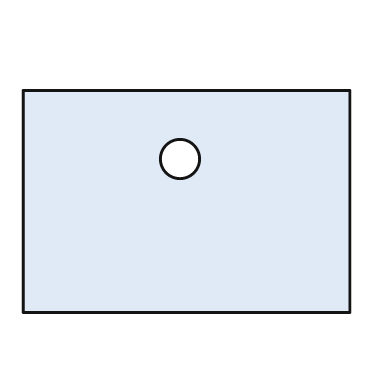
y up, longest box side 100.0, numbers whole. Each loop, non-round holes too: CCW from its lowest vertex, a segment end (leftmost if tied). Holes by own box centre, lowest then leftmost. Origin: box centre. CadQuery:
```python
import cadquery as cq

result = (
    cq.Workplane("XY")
    .moveTo(-50.0, -34.0)
    .lineTo(50.0, -34.0)
    .lineTo(50.0, 34.0)
    .lineTo(-50.0, 34.0)
    .close()
    .moveTo(-2.0, 13.0)
    .circle(6.0)
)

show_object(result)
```